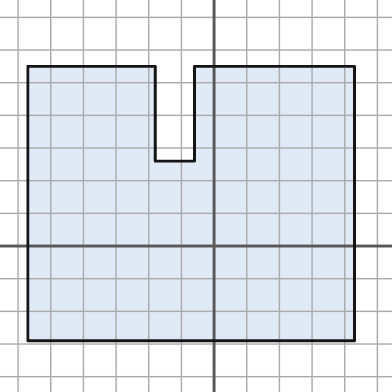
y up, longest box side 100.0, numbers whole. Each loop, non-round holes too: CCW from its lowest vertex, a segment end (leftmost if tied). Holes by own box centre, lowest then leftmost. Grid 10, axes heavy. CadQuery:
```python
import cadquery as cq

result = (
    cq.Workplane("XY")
    .moveTo(-57.0, -29.0)
    .lineTo(43.0, -29.0)
    .lineTo(43.0, 55.0)
    .lineTo(-6.0, 55.0)
    .lineTo(-6.0, 26.0)
    .lineTo(-18.0, 26.0)
    .lineTo(-18.0, 55.0)
    .lineTo(-57.0, 55.0)
    .close()
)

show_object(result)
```